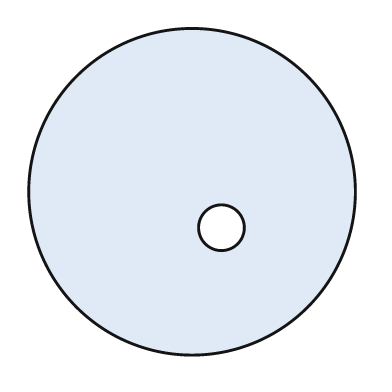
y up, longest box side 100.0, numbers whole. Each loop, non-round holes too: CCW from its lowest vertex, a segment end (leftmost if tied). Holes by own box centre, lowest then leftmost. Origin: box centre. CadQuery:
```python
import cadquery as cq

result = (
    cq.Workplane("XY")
    .moveTo(0.0, 0.0)
    .circle(50.0)
    .moveTo(9.0, -11.0)
    .circle(7.0)
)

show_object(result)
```